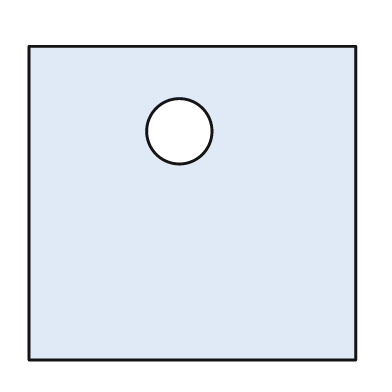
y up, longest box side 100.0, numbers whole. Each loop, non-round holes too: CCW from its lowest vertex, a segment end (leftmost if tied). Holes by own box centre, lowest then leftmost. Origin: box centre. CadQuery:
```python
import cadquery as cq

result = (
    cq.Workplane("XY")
    .moveTo(-50.0, -48.0)
    .lineTo(50.0, -48.0)
    .lineTo(50.0, 48.0)
    .lineTo(-50.0, 48.0)
    .close()
    .moveTo(-4.0, 22.0)
    .circle(10.0)
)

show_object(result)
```